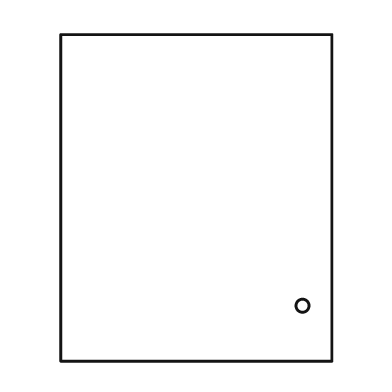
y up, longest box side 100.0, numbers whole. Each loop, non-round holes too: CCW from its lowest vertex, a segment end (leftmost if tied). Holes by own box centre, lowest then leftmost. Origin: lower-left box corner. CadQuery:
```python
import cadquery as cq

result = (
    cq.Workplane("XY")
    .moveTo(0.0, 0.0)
    .lineTo(83.0, 0.0)
    .lineTo(83.0, 100.0)
    .lineTo(0.0, 100.0)
    .close()
    .moveTo(74.0, 17.0)
    .circle(2.0)
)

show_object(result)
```